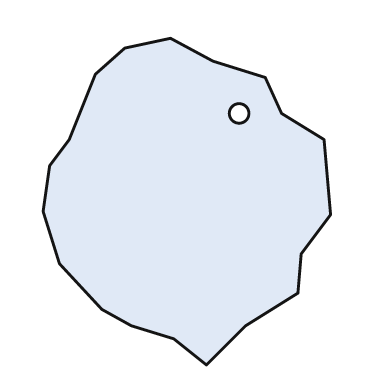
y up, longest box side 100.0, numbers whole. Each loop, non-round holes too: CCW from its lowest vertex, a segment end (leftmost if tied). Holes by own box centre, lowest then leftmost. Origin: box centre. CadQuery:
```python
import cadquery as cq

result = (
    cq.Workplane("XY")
    .moveTo(6.0, -50.0)
    .lineTo(18.0, -38.0)
    .lineTo(34.0, -28.0)
    .lineTo(35.0, -16.0)
    .lineTo(44.0, -4.0)
    .lineTo(42.0, 19.0)
    .lineTo(29.0, 27.0)
    .lineTo(24.0, 38.0)
    .lineTo(8.0, 43.0)
    .lineTo(-5.0, 50.0)
    .lineTo(-19.0, 47.0)
    .lineTo(-28.0, 39.0)
    .lineTo(-36.0, 19.0)
    .lineTo(-42.0, 11.0)
    .lineTo(-44.0, -3.0)
    .lineTo(-39.0, -19.0)
    .lineTo(-26.0, -33.0)
    .lineTo(-17.0, -38.0)
    .lineTo(-4.0, -42.0)
    .close()
    .moveTo(16.0, 27.0)
    .circle(3.0)
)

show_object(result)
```